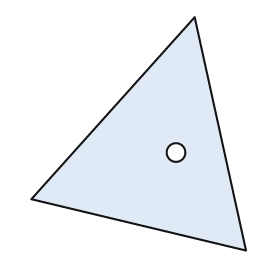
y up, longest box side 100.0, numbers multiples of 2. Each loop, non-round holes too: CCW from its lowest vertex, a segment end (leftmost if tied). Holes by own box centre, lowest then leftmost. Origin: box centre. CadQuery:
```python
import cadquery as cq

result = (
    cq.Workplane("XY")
    .moveTo(46.0, -50.0)
    .lineTo(24.0, 50.0)
    .lineTo(-46.0, -28.0)
    .close()
    .moveTo(16.0, -8.0)
    .circle(4.0)
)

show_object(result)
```